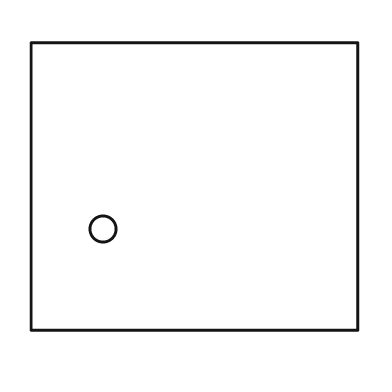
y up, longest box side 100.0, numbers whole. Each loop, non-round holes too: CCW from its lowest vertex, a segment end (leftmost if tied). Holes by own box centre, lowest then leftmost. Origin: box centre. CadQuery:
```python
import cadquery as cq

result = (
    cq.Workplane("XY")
    .moveTo(-50.0, -44.0)
    .lineTo(50.0, -44.0)
    .lineTo(50.0, 44.0)
    .lineTo(-50.0, 44.0)
    .close()
    .moveTo(-28.0, -13.0)
    .circle(4.0)
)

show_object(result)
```